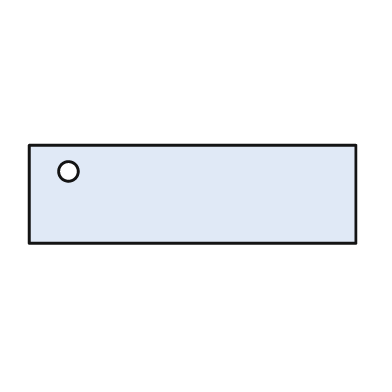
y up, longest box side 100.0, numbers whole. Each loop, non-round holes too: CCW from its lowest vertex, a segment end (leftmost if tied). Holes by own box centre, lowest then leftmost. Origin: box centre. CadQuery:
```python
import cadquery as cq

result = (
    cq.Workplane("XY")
    .moveTo(-50.0, -15.0)
    .lineTo(50.0, -15.0)
    .lineTo(50.0, 15.0)
    .lineTo(-50.0, 15.0)
    .close()
    .moveTo(-38.0, 7.0)
    .circle(3.0)
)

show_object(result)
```